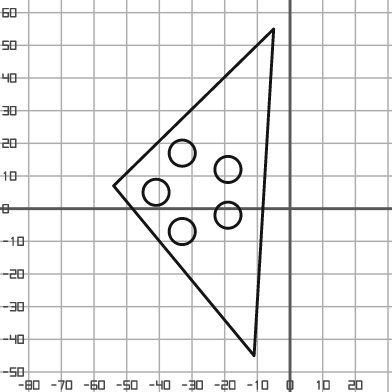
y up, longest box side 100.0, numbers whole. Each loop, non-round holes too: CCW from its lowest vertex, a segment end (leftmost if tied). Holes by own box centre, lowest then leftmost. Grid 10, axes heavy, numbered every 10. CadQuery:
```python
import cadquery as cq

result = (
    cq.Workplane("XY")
    .moveTo(-11.0, -45.0)
    .lineTo(-5.0, 55.0)
    .lineTo(-54.0, 7.0)
    .close()
    .moveTo(-33.0, -7.0)
    .circle(4.0)
    .moveTo(-19.0, -2.0)
    .circle(4.0)
    .moveTo(-41.0, 5.0)
    .circle(4.0)
    .moveTo(-19.0, 12.0)
    .circle(4.0)
    .moveTo(-33.0, 17.0)
    .circle(4.0)
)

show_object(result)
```